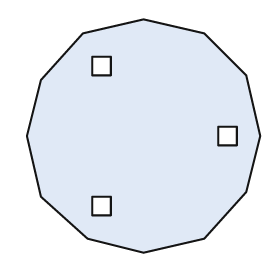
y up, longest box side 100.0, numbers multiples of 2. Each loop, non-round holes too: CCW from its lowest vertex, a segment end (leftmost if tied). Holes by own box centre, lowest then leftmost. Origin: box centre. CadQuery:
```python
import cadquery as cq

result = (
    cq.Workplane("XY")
    .moveTo(0.0, -50.0)
    .lineTo(26.0, -44.0)
    .lineTo(44.0, -24.0)
    .lineTo(50.0, 0.0)
    .lineTo(44.0, 26.0)
    .lineTo(26.0, 44.0)
    .lineTo(0.0, 50.0)
    .lineTo(-26.0, 44.0)
    .lineTo(-44.0, 24.0)
    .lineTo(-50.0, 0.0)
    .lineTo(-44.0, -26.0)
    .lineTo(-24.0, -44.0)
    .close()
    .moveTo(-22.0, -34.0)
    .lineTo(-14.0, -34.0)
    .lineTo(-14.0, -26.0)
    .lineTo(-22.0, -26.0)
    .close()
    .moveTo(32.0, -4.0)
    .lineTo(40.0, -4.0)
    .lineTo(40.0, 4.0)
    .lineTo(32.0, 4.0)
    .close()
    .moveTo(-22.0, 26.0)
    .lineTo(-14.0, 26.0)
    .lineTo(-14.0, 34.0)
    .lineTo(-22.0, 34.0)
    .close()
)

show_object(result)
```